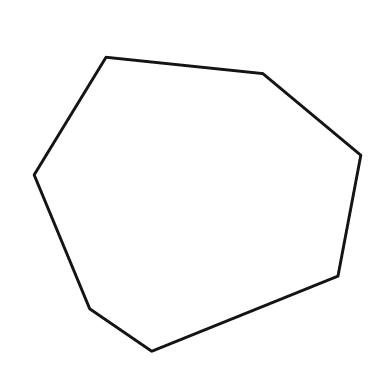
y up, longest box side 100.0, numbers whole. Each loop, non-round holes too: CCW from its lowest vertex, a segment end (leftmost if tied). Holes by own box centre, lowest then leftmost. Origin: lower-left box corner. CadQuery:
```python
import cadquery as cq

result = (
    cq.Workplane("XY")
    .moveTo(36.0, 0.0)
    .lineTo(93.0, 23.0)
    .lineTo(100.0, 60.0)
    .lineTo(70.0, 85.0)
    .lineTo(22.0, 90.0)
    .lineTo(0.0, 54.0)
    .lineTo(17.0, 13.0)
    .close()
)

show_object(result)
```